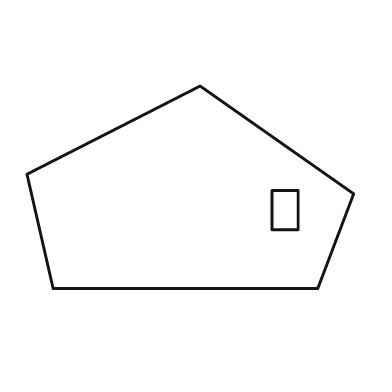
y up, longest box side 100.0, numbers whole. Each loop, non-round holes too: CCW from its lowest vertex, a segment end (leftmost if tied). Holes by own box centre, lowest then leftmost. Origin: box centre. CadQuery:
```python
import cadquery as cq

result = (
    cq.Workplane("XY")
    .moveTo(-42.0, -31.0)
    .lineTo(39.0, -31.0)
    .lineTo(50.0, -2.0)
    .lineTo(3.0, 31.0)
    .lineTo(-50.0, 4.0)
    .close()
    .moveTo(25.0, -13.0)
    .lineTo(33.0, -13.0)
    .lineTo(33.0, -1.0)
    .lineTo(25.0, -1.0)
    .close()
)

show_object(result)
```